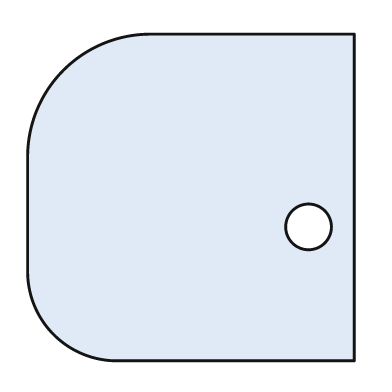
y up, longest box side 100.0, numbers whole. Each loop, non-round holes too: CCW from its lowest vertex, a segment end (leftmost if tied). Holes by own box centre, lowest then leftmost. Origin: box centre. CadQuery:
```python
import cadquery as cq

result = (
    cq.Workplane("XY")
    .moveTo(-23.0, -50.0)
    .lineTo(50.0, -50.0)
    .lineTo(50.0, 50.0)
    .lineTo(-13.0, 50.0)
    .threePointArc((-39.0, 39.0), (-50.0, 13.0))
    .lineTo(-50.0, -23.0)
    .threePointArc((-42.0, -42.0), (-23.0, -50.0))
    .close()
    .moveTo(36.0, -9.0)
    .circle(7.0)
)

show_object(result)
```